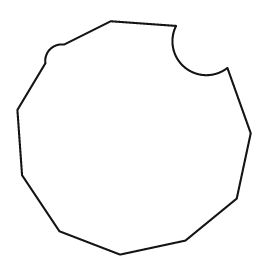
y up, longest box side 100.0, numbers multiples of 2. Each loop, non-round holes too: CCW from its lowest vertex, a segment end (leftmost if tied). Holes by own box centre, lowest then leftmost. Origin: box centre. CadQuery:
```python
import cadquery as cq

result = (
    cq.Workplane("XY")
    .moveTo(-6.0, -50.0)
    .lineTo(22.0, -44.0)
    .lineTo(44.0, -26.0)
    .lineTo(50.0, 2.0)
    .lineTo(40.0, 30.0)
    .threePointArc((22.0, 30.0), (18.0, 48.0))
    .lineTo(-10.0, 50.0)
    .lineTo(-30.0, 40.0)
    .threePointArc((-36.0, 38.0), (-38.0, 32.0))
    .lineTo(-50.0, 12.0)
    .lineTo(-48.0, -16.0)
    .lineTo(-32.0, -40.0)
    .close()
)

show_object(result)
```